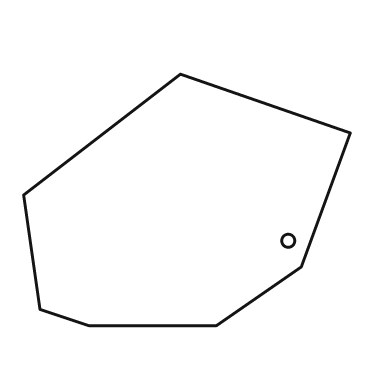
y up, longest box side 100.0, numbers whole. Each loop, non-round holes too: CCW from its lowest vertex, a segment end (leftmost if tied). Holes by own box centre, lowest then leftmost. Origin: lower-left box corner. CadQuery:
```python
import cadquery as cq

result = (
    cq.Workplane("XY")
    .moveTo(20.0, 0.0)
    .lineTo(59.0, 0.0)
    .lineTo(85.0, 18.0)
    .lineTo(100.0, 59.0)
    .lineTo(48.0, 77.0)
    .lineTo(0.0, 40.0)
    .lineTo(5.0, 5.0)
    .close()
    .moveTo(81.0, 26.0)
    .circle(2.0)
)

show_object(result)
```